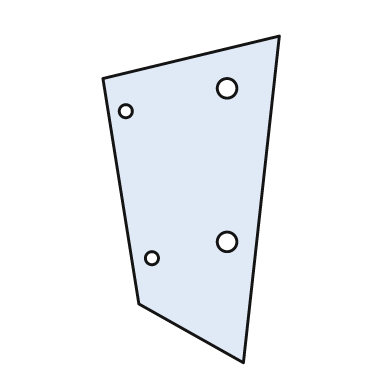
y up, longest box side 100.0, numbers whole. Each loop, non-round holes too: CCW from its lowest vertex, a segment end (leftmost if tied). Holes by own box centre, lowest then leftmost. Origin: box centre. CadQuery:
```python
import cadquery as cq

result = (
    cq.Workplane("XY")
    .moveTo(16.0, -50.0)
    .lineTo(27.0, 50.0)
    .lineTo(-27.0, 37.0)
    .lineTo(-16.0, -32.0)
    .close()
    .moveTo(-12.0, -18.0)
    .circle(2.0)
    .moveTo(11.0, -13.0)
    .circle(3.0)
    .moveTo(-20.0, 27.0)
    .circle(2.0)
    .moveTo(11.0, 34.0)
    .circle(3.0)
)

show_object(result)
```